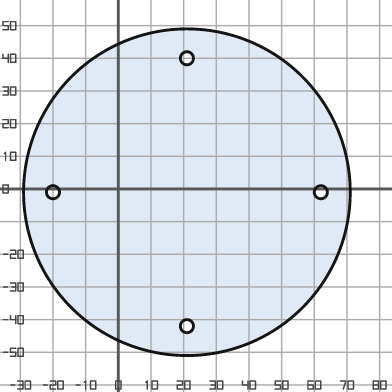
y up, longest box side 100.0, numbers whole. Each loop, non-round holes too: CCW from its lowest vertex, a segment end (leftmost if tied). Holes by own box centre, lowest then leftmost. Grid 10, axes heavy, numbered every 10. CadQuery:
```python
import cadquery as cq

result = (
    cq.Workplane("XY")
    .moveTo(21.0, -1.0)
    .circle(50.0)
    .moveTo(21.0, -42.0)
    .circle(2.0)
    .moveTo(-20.0, -1.0)
    .circle(2.0)
    .moveTo(62.0, -1.0)
    .circle(2.0)
    .moveTo(21.0, 40.0)
    .circle(2.0)
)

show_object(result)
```